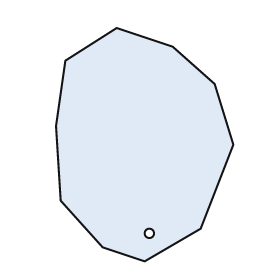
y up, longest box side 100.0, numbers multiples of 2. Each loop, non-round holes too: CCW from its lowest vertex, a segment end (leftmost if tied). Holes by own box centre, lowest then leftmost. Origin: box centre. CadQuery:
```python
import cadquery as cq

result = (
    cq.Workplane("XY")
    .moveTo(0.0, -50.0)
    .lineTo(24.0, -36.0)
    .lineTo(38.0, 0.0)
    .lineTo(30.0, 26.0)
    .lineTo(12.0, 42.0)
    .lineTo(-12.0, 50.0)
    .lineTo(-34.0, 36.0)
    .lineTo(-38.0, 8.0)
    .lineTo(-36.0, -24.0)
    .lineTo(-18.0, -44.0)
    .close()
    .moveTo(2.0, -38.0)
    .circle(2.0)
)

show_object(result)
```